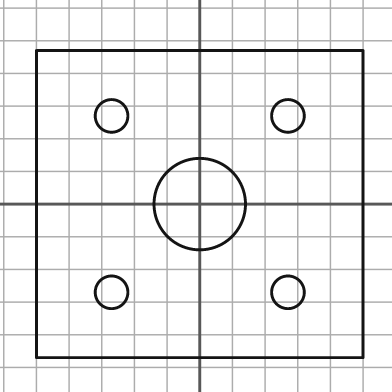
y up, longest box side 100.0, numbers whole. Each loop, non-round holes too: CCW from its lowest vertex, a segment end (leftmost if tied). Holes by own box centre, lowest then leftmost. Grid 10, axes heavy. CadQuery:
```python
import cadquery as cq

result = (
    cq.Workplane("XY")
    .moveTo(-50.0, -47.0)
    .lineTo(50.0, -47.0)
    .lineTo(50.0, 47.0)
    .lineTo(-50.0, 47.0)
    .close()
    .moveTo(-27.0, -27.0)
    .circle(5.0)
    .moveTo(27.0, -27.0)
    .circle(5.0)
    .moveTo(0.0, 0.0)
    .circle(14.0)
    .moveTo(-27.0, 27.0)
    .circle(5.0)
    .moveTo(27.0, 27.0)
    .circle(5.0)
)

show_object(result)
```